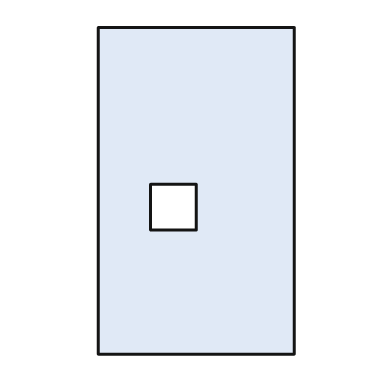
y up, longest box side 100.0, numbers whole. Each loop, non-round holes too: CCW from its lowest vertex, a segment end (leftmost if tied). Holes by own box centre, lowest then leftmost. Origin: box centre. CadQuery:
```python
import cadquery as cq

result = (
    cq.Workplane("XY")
    .moveTo(-30.0, -50.0)
    .lineTo(30.0, -50.0)
    .lineTo(30.0, 50.0)
    .lineTo(-30.0, 50.0)
    .close()
    .moveTo(-14.0, -12.0)
    .lineTo(0.0, -12.0)
    .lineTo(0.0, 2.0)
    .lineTo(-14.0, 2.0)
    .close()
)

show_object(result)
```